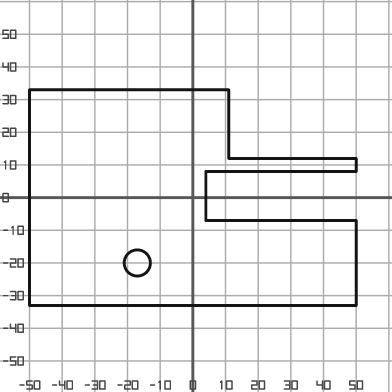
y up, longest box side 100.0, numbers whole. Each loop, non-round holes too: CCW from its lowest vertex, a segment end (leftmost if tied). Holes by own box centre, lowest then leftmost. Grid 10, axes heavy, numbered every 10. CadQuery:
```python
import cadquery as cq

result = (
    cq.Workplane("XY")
    .moveTo(-50.0, -33.0)
    .lineTo(50.0, -33.0)
    .lineTo(50.0, -7.0)
    .lineTo(4.0, -7.0)
    .lineTo(4.0, 8.0)
    .lineTo(50.0, 8.0)
    .lineTo(50.0, 12.0)
    .lineTo(11.0, 12.0)
    .lineTo(11.0, 33.0)
    .lineTo(-50.0, 33.0)
    .close()
    .moveTo(-17.0, -20.0)
    .circle(4.0)
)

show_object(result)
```